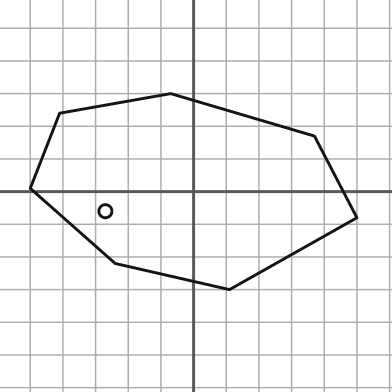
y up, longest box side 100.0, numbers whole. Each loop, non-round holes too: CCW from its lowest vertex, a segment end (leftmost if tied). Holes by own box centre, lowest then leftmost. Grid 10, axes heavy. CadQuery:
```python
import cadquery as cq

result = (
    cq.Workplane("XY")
    .moveTo(11.0, -30.0)
    .lineTo(50.0, -8.0)
    .lineTo(37.0, 17.0)
    .lineTo(-7.0, 30.0)
    .lineTo(-41.0, 24.0)
    .lineTo(-50.0, 1.0)
    .lineTo(-24.0, -22.0)
    .close()
    .moveTo(-27.0, -6.0)
    .circle(2.0)
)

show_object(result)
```